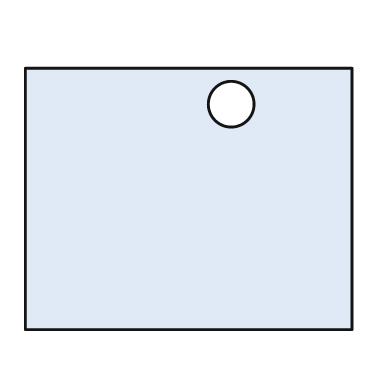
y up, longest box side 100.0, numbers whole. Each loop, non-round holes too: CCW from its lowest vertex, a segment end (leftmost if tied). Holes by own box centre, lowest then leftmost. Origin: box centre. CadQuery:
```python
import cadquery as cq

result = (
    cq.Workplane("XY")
    .moveTo(-50.0, -40.0)
    .lineTo(50.0, -40.0)
    .lineTo(50.0, 40.0)
    .lineTo(-50.0, 40.0)
    .close()
    .moveTo(13.0, 29.0)
    .circle(7.0)
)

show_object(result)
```